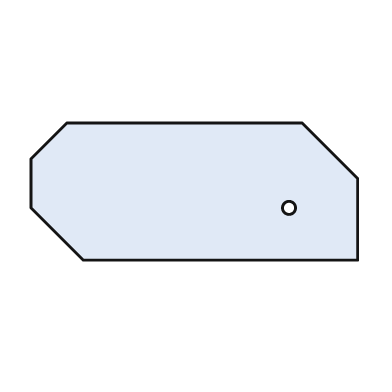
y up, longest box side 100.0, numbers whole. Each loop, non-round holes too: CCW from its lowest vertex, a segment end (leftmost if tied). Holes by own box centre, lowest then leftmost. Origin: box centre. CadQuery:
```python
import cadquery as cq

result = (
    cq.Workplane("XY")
    .moveTo(-34.0, -21.0)
    .lineTo(50.0, -21.0)
    .lineTo(50.0, 4.0)
    .lineTo(33.0, 21.0)
    .lineTo(-39.0, 21.0)
    .lineTo(-50.0, 10.0)
    .lineTo(-50.0, -5.0)
    .close()
    .moveTo(29.0, -5.0)
    .circle(2.0)
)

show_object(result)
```